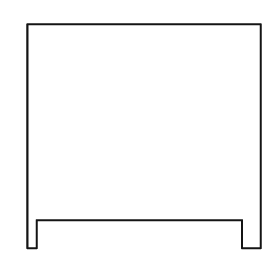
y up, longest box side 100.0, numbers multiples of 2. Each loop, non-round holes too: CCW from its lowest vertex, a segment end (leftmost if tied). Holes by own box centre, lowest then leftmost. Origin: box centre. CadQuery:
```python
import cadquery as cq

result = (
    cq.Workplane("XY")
    .moveTo(-50.0, -48.0)
    .lineTo(-46.0, -48.0)
    .lineTo(-46.0, -36.0)
    .lineTo(42.0, -36.0)
    .lineTo(42.0, -48.0)
    .lineTo(50.0, -48.0)
    .lineTo(50.0, 48.0)
    .lineTo(-50.0, 48.0)
    .close()
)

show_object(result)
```